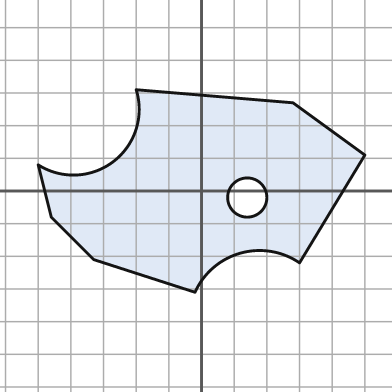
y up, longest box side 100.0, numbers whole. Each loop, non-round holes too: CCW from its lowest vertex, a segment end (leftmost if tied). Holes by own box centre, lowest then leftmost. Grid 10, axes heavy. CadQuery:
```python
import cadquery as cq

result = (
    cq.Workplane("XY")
    .moveTo(-2.0, -31.0)
    .threePointArc((12.0, -19.0), (30.0, -22.0))
    .lineTo(50.0, 11.0)
    .lineTo(28.0, 27.0)
    .lineTo(-20.0, 31.0)
    .threePointArc((-27.0, 9.0), (-50.0, 8.0))
    .lineTo(-46.0, -8.0)
    .lineTo(-33.0, -21.0)
    .close()
    .moveTo(14.0, -2.0)
    .circle(6.0)
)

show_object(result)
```